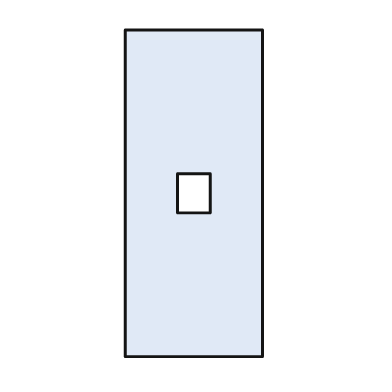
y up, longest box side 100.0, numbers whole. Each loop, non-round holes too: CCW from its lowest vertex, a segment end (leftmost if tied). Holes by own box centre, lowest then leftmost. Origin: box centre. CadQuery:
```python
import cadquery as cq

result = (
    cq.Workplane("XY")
    .moveTo(-21.0, -50.0)
    .lineTo(21.0, -50.0)
    .lineTo(21.0, 50.0)
    .lineTo(-21.0, 50.0)
    .close()
    .moveTo(-5.0, -6.0)
    .lineTo(5.0, -6.0)
    .lineTo(5.0, 6.0)
    .lineTo(-5.0, 6.0)
    .close()
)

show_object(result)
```